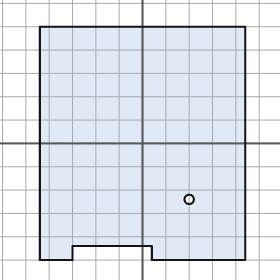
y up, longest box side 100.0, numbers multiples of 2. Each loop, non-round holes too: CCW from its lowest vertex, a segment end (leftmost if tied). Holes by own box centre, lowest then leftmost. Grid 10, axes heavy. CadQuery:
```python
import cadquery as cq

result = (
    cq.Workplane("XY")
    .moveTo(-44.0, -50.0)
    .lineTo(-30.0, -50.0)
    .lineTo(-30.0, -44.0)
    .lineTo(4.0, -44.0)
    .lineTo(4.0, -50.0)
    .lineTo(44.0, -50.0)
    .lineTo(44.0, 50.0)
    .lineTo(-44.0, 50.0)
    .close()
    .moveTo(20.0, -24.0)
    .circle(2.0)
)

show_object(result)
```